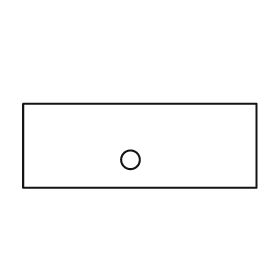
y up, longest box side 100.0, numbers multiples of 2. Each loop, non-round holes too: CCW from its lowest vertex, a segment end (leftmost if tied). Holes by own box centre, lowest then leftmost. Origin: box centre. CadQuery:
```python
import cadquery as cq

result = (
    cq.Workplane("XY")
    .moveTo(-50.0, -18.0)
    .lineTo(50.0, -18.0)
    .lineTo(50.0, 18.0)
    .lineTo(-50.0, 18.0)
    .close()
    .moveTo(-4.0, -6.0)
    .circle(4.0)
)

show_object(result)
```